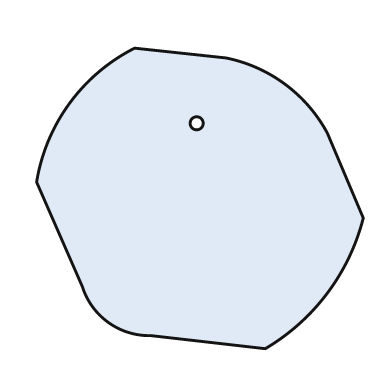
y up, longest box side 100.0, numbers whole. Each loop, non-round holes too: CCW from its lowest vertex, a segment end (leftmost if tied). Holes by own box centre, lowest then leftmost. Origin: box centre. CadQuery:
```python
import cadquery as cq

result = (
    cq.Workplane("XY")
    .moveTo(20.0, -46.0)
    .threePointArc((39.0, -29.0), (50.0, -6.0))
    .lineTo(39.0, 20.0)
    .threePointArc((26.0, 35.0), (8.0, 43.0))
    .lineTo(-20.0, 46.0)
    .threePointArc((-40.0, 29.0), (-50.0, 5.0))
    .lineTo(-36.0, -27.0)
    .threePointArc((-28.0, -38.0), (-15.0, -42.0))
    .close()
    .moveTo(-1.0, 23.0)
    .circle(2.0)
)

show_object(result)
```